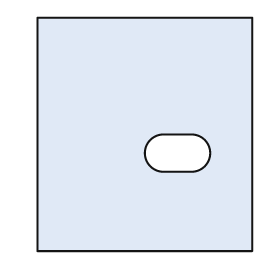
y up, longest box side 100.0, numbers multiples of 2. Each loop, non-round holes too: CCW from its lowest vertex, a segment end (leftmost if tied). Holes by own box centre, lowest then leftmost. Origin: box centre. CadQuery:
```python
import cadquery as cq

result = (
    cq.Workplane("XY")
    .moveTo(-46.0, -50.0)
    .lineTo(46.0, -50.0)
    .lineTo(46.0, 50.0)
    .lineTo(-46.0, 50.0)
    .close()
    .moveTo(8.0, -16.0)
    .lineTo(20.0, -16.0)
    .threePointArc((28.0, -8.0), (20.0, 0.0))
    .lineTo(8.0, 0.0)
    .threePointArc((0.0, -8.0), (8.0, -16.0))
    .close()
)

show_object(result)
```